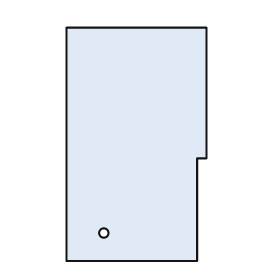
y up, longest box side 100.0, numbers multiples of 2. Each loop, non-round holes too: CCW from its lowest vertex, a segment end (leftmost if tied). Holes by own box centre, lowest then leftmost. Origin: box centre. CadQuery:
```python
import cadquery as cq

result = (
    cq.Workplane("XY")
    .moveTo(-30.0, -50.0)
    .lineTo(26.0, -50.0)
    .lineTo(26.0, -6.0)
    .lineTo(30.0, -6.0)
    .lineTo(30.0, 50.0)
    .lineTo(-30.0, 50.0)
    .close()
    .moveTo(-14.0, -38.0)
    .circle(2.0)
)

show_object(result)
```